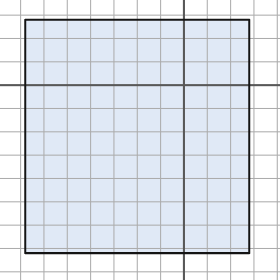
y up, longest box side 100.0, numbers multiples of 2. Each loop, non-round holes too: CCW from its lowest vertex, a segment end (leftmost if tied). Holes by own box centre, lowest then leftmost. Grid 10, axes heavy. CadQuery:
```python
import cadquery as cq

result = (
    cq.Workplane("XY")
    .moveTo(-68.0, -72.0)
    .lineTo(28.0, -72.0)
    .lineTo(28.0, 28.0)
    .lineTo(-68.0, 28.0)
    .close()
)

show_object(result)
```